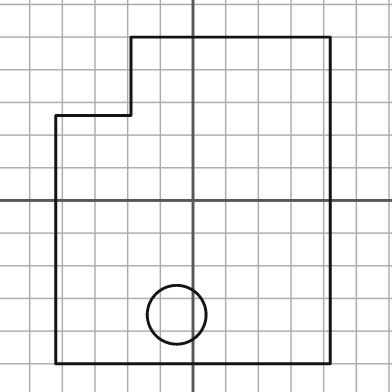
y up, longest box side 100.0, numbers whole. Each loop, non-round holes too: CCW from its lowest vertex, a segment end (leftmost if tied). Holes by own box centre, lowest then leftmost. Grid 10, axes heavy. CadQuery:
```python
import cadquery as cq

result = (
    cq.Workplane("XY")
    .moveTo(-42.0, -50.0)
    .lineTo(42.0, -50.0)
    .lineTo(42.0, 50.0)
    .lineTo(-19.0, 50.0)
    .lineTo(-19.0, 26.0)
    .lineTo(-42.0, 26.0)
    .close()
    .moveTo(-5.0, -35.0)
    .circle(9.0)
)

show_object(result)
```